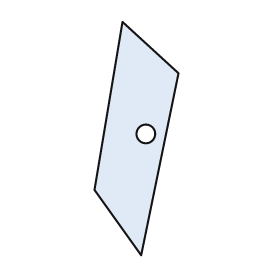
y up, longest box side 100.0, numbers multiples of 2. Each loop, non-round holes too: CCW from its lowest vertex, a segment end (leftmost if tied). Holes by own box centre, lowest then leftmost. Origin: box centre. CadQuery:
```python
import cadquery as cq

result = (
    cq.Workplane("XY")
    .moveTo(2.0, -50.0)
    .lineTo(18.0, 28.0)
    .lineTo(-6.0, 50.0)
    .lineTo(-18.0, -22.0)
    .close()
    .moveTo(4.0, 2.0)
    .circle(4.0)
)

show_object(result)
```